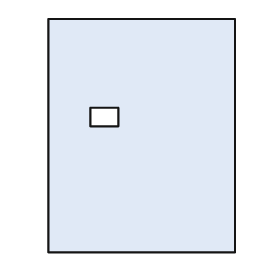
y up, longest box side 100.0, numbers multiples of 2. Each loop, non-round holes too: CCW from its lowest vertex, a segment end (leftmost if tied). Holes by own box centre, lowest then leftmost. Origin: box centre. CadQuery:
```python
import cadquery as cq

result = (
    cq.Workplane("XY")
    .moveTo(-40.0, -50.0)
    .lineTo(40.0, -50.0)
    .lineTo(40.0, 50.0)
    .lineTo(-40.0, 50.0)
    .close()
    .moveTo(-22.0, 4.0)
    .lineTo(-10.0, 4.0)
    .lineTo(-10.0, 12.0)
    .lineTo(-22.0, 12.0)
    .close()
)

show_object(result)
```